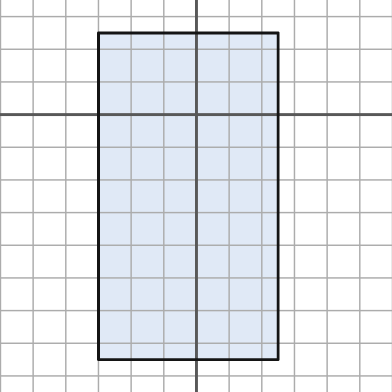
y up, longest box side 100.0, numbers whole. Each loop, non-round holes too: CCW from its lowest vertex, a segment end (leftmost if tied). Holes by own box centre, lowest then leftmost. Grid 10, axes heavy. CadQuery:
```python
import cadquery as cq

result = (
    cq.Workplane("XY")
    .moveTo(-30.0, -75.0)
    .lineTo(25.0, -75.0)
    .lineTo(25.0, 25.0)
    .lineTo(-30.0, 25.0)
    .close()
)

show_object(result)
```